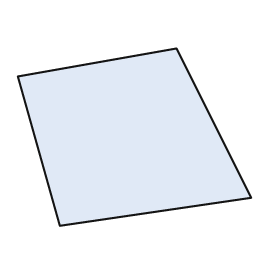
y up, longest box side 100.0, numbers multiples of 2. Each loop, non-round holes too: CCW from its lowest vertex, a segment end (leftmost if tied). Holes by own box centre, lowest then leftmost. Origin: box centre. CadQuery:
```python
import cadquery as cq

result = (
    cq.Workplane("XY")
    .moveTo(-32.0, -38.0)
    .lineTo(50.0, -26.0)
    .lineTo(18.0, 38.0)
    .lineTo(-50.0, 26.0)
    .close()
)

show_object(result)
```